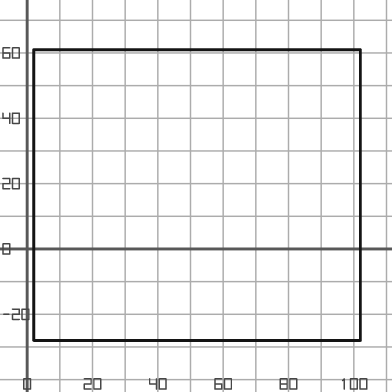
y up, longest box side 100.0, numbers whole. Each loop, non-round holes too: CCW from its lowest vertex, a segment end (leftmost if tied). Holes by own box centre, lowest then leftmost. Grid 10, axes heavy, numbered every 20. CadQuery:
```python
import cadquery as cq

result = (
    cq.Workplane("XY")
    .moveTo(2.0, -28.0)
    .lineTo(102.0, -28.0)
    .lineTo(102.0, 61.0)
    .lineTo(2.0, 61.0)
    .close()
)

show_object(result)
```